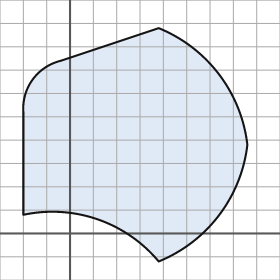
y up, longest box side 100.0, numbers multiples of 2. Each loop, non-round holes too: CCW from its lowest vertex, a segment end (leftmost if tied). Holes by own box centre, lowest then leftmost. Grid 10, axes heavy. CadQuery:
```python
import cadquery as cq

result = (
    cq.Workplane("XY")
    .moveTo(38.0, -12.0)
    .threePointArc((64.0, 8.0), (76.0, 38.0))
    .threePointArc((64.0, 68.0), (38.0, 88.0))
    .lineTo(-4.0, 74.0)
    .threePointArc((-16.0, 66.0), (-20.0, 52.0))
    .lineTo(-20.0, 8.0)
    .threePointArc((12.0, 6.0), (38.0, -12.0))
    .close()
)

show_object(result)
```